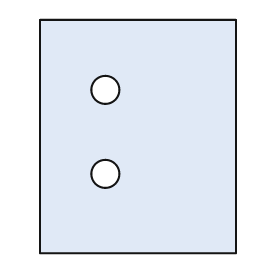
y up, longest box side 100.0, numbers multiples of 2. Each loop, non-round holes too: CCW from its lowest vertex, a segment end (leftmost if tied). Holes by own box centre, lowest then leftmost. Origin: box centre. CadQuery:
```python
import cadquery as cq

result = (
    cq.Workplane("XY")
    .moveTo(-42.0, -50.0)
    .lineTo(42.0, -50.0)
    .lineTo(42.0, 50.0)
    .lineTo(-42.0, 50.0)
    .close()
    .moveTo(-14.0, -16.0)
    .circle(6.0)
    .moveTo(-14.0, 20.0)
    .circle(6.0)
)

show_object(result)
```